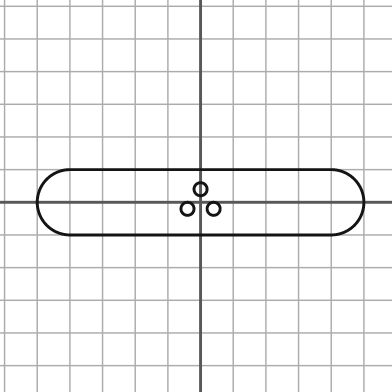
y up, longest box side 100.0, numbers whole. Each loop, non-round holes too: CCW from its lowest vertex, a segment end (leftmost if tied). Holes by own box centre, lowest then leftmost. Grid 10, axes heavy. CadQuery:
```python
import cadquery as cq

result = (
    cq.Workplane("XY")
    .moveTo(-40.0, -10.0)
    .lineTo(40.0, -10.0)
    .threePointArc((50.0, 0.0), (40.0, 10.0))
    .lineTo(-40.0, 10.0)
    .threePointArc((-50.0, 0.0), (-40.0, -10.0))
    .close()
    .moveTo(-4.0, -2.0)
    .circle(2.0)
    .moveTo(4.0, -2.0)
    .circle(2.0)
    .moveTo(0.0, 4.0)
    .circle(2.0)
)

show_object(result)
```